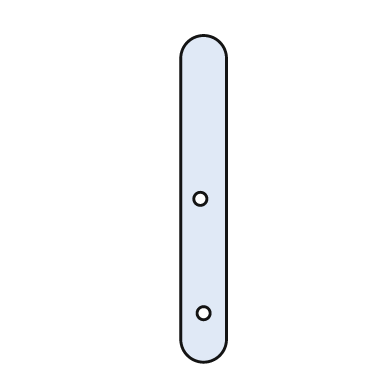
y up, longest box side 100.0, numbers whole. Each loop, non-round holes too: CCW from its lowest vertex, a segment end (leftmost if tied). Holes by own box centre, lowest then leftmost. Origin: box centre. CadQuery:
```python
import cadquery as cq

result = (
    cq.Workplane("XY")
    .moveTo(-7.0, -43.0)
    .threePointArc((0.0, -50.0), (7.0, -43.0))
    .lineTo(7.0, 43.0)
    .threePointArc((0.0, 50.0), (-7.0, 43.0))
    .close()
    .moveTo(0.0, -35.0)
    .circle(2.0)
    .moveTo(-1.0, 0.0)
    .circle(2.0)
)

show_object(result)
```